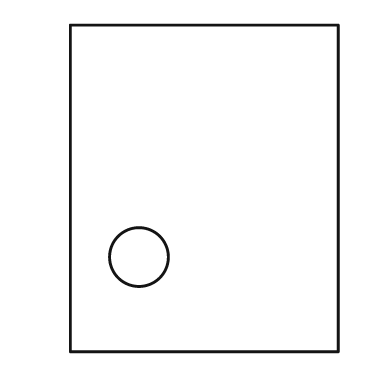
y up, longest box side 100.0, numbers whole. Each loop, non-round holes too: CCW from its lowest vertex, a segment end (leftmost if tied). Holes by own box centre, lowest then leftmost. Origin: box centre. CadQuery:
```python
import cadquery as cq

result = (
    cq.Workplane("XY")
    .moveTo(-41.0, -50.0)
    .lineTo(41.0, -50.0)
    .lineTo(41.0, 50.0)
    .lineTo(-41.0, 50.0)
    .close()
    .moveTo(-20.0, -21.0)
    .circle(9.0)
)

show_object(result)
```